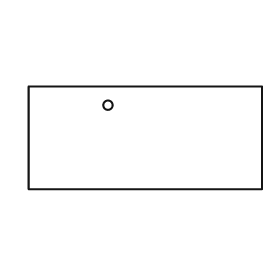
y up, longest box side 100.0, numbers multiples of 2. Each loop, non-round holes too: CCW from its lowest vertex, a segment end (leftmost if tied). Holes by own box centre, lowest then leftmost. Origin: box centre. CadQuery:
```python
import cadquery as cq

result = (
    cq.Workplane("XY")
    .moveTo(-50.0, -22.0)
    .lineTo(50.0, -22.0)
    .lineTo(50.0, 22.0)
    .lineTo(-50.0, 22.0)
    .close()
    .moveTo(-16.0, 14.0)
    .circle(2.0)
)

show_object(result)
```